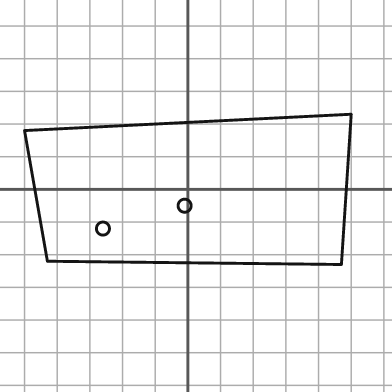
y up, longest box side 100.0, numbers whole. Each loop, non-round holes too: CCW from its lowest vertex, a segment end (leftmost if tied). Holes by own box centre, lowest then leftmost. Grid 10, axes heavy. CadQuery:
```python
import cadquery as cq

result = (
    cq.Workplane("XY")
    .moveTo(47.0, -23.0)
    .lineTo(50.0, 23.0)
    .lineTo(-50.0, 18.0)
    .lineTo(-43.0, -22.0)
    .close()
    .moveTo(-26.0, -12.0)
    .circle(2.0)
    .moveTo(-1.0, -5.0)
    .circle(2.0)
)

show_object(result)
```